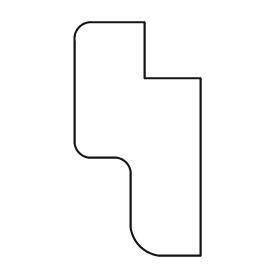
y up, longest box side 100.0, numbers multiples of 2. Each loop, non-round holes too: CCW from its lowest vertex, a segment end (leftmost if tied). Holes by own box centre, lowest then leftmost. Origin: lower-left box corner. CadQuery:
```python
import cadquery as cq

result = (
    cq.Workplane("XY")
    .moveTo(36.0, 0.0)
    .lineTo(54.0, 0.0)
    .lineTo(54.0, 76.0)
    .lineTo(30.0, 76.0)
    .lineTo(30.0, 100.0)
    .lineTo(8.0, 100.0)
    .threePointArc((2.0, 98.0), (0.0, 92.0))
    .lineTo(0.0, 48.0)
    .threePointArc((2.0, 44.0), (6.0, 42.0))
    .lineTo(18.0, 42.0)
    .threePointArc((22.0, 40.0), (24.0, 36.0))
    .lineTo(24.0, 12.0)
    .threePointArc((28.0, 4.0), (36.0, 0.0))
    .close()
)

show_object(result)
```